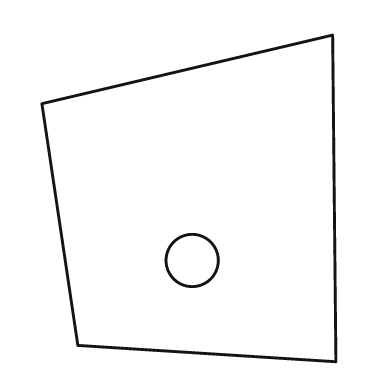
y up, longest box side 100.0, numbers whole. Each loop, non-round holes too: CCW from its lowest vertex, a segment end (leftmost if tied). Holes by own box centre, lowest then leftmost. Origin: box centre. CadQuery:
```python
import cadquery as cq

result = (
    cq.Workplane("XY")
    .moveTo(45.0, -50.0)
    .lineTo(44.0, 50.0)
    .lineTo(-45.0, 29.0)
    .lineTo(-34.0, -45.0)
    .close()
    .moveTo(1.0, -19.0)
    .circle(8.0)
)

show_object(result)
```